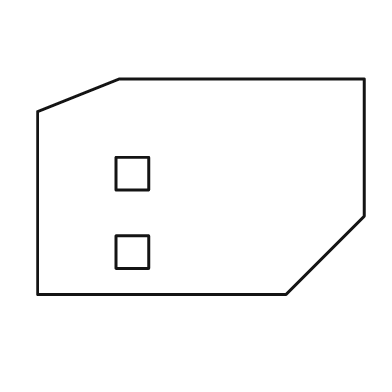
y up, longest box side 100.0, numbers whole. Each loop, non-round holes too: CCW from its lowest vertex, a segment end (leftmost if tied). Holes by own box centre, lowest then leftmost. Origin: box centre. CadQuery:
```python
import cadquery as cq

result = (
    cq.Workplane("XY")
    .moveTo(-50.0, -33.0)
    .lineTo(26.0, -33.0)
    .lineTo(50.0, -9.0)
    .lineTo(50.0, 33.0)
    .lineTo(-25.0, 33.0)
    .lineTo(-50.0, 23.0)
    .close()
    .moveTo(-26.0, -25.0)
    .lineTo(-16.0, -25.0)
    .lineTo(-16.0, -15.0)
    .lineTo(-26.0, -15.0)
    .close()
    .moveTo(-26.0, -1.0)
    .lineTo(-16.0, -1.0)
    .lineTo(-16.0, 9.0)
    .lineTo(-26.0, 9.0)
    .close()
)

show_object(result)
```